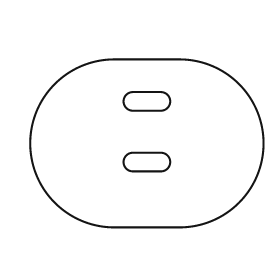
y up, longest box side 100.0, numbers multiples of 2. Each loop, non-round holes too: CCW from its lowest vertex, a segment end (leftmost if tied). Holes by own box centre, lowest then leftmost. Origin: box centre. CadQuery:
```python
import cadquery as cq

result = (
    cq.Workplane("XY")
    .moveTo(-14.0, -36.0)
    .lineTo(14.0, -36.0)
    .threePointArc((50.0, 0.0), (14.0, 36.0))
    .lineTo(-14.0, 36.0)
    .threePointArc((-50.0, 0.0), (-14.0, -36.0))
    .close()
    .moveTo(-6.0, -12.0)
    .lineTo(6.0, -12.0)
    .threePointArc((10.0, -8.0), (6.0, -4.0))
    .lineTo(-6.0, -4.0)
    .threePointArc((-10.0, -8.0), (-6.0, -12.0))
    .close()
    .moveTo(-6.0, 14.0)
    .lineTo(6.0, 14.0)
    .threePointArc((10.0, 18.0), (6.0, 22.0))
    .lineTo(-6.0, 22.0)
    .threePointArc((-10.0, 18.0), (-6.0, 14.0))
    .close()
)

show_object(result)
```